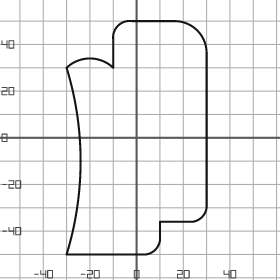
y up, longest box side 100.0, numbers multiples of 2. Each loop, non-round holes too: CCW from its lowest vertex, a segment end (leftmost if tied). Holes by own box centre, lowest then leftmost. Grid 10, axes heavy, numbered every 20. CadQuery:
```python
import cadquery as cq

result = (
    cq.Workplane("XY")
    .moveTo(-30.0, -50.0)
    .lineTo(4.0, -50.0)
    .threePointArc((8.0, -48.0), (10.0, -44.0))
    .lineTo(10.0, -36.0)
    .lineTo(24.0, -36.0)
    .threePointArc((28.0, -34.0), (30.0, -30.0))
    .lineTo(30.0, 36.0)
    .threePointArc((26.0, 46.0), (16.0, 50.0))
    .lineTo(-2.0, 50.0)
    .threePointArc((-8.0, 48.0), (-10.0, 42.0))
    .lineTo(-10.0, 30.0)
    .threePointArc((-20.0, 34.0), (-30.0, 30.0))
    .threePointArc((-24.0, -10.0), (-30.0, -50.0))
    .close()
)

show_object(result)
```